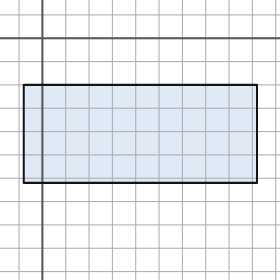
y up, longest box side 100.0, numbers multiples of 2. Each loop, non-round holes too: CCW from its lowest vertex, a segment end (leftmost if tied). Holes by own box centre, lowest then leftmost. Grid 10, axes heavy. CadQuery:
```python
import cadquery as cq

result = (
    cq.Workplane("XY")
    .moveTo(-8.0, -62.0)
    .lineTo(92.0, -62.0)
    .lineTo(92.0, -20.0)
    .lineTo(-8.0, -20.0)
    .close()
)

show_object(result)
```